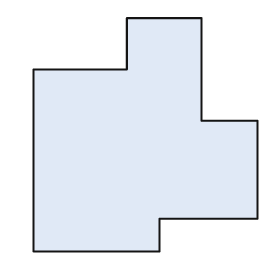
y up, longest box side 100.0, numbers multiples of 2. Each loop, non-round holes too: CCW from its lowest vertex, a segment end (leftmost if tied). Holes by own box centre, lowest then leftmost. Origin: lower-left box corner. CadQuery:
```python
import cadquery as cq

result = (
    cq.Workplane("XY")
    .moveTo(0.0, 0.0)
    .lineTo(54.0, 0.0)
    .lineTo(54.0, 14.0)
    .lineTo(96.0, 14.0)
    .lineTo(96.0, 56.0)
    .lineTo(72.0, 56.0)
    .lineTo(72.0, 100.0)
    .lineTo(40.0, 100.0)
    .lineTo(40.0, 78.0)
    .lineTo(0.0, 78.0)
    .close()
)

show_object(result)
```